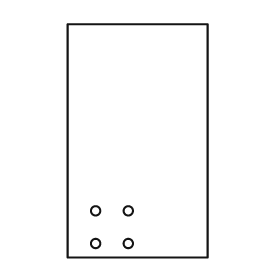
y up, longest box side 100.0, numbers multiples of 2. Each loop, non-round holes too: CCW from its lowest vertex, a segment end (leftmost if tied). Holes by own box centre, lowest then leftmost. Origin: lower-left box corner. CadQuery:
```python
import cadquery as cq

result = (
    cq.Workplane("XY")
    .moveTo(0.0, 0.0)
    .lineTo(60.0, 0.0)
    .lineTo(60.0, 100.0)
    .lineTo(0.0, 100.0)
    .close()
    .moveTo(12.0, 6.0)
    .circle(2.0)
    .moveTo(26.0, 6.0)
    .circle(2.0)
    .moveTo(12.0, 20.0)
    .circle(2.0)
    .moveTo(26.0, 20.0)
    .circle(2.0)
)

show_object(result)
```